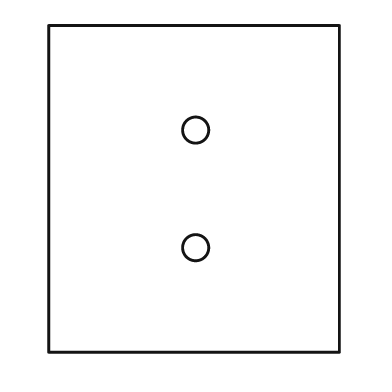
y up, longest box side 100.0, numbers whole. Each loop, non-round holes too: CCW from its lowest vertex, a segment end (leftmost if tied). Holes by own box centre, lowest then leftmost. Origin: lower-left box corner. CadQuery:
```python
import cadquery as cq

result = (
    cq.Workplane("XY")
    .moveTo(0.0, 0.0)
    .lineTo(89.0, 0.0)
    .lineTo(89.0, 100.0)
    .lineTo(0.0, 100.0)
    .close()
    .moveTo(45.0, 32.0)
    .circle(4.0)
    .moveTo(45.0, 68.0)
    .circle(4.0)
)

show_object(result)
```